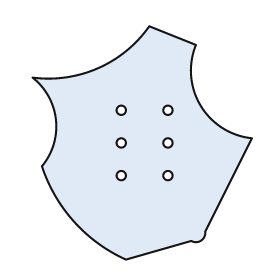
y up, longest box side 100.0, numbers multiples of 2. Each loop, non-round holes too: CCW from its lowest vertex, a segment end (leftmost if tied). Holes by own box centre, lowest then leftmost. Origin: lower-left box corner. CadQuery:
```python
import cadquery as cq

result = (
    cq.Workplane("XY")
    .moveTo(40.0, 0.0)
    .lineTo(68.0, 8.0)
    .threePointArc((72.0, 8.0), (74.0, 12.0))
    .lineTo(94.0, 52.0)
    .threePointArc((72.0, 66.0), (70.0, 92.0))
    .lineTo(50.0, 100.0)
    .threePointArc((28.0, 82.0), (0.0, 78.0))
    .threePointArc((10.0, 60.0), (4.0, 40.0))
    .threePointArc((18.0, 16.0), (40.0, 0.0))
    .close()
    .moveTo(38.0, 36.0)
    .circle(2.0)
    .moveTo(58.0, 36.0)
    .circle(2.0)
    .moveTo(38.0, 50.0)
    .circle(2.0)
    .moveTo(58.0, 50.0)
    .circle(2.0)
    .moveTo(38.0, 64.0)
    .circle(2.0)
    .moveTo(58.0, 64.0)
    .circle(2.0)
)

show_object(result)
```